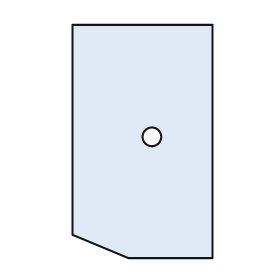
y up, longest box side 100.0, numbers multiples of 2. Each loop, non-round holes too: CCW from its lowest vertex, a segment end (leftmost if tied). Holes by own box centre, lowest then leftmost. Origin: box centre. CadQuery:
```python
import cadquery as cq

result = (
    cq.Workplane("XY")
    .moveTo(-6.0, -50.0)
    .lineTo(30.0, -50.0)
    .lineTo(30.0, 50.0)
    .lineTo(-30.0, 50.0)
    .lineTo(-30.0, -40.0)
    .close()
    .moveTo(4.0, 2.0)
    .circle(4.0)
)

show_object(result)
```